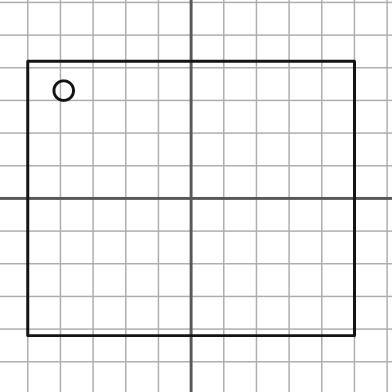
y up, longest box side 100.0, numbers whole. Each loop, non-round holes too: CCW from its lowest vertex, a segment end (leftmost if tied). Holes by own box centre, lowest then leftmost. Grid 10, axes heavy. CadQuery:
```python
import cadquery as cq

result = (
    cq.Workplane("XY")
    .moveTo(-50.0, -42.0)
    .lineTo(50.0, -42.0)
    .lineTo(50.0, 42.0)
    .lineTo(-50.0, 42.0)
    .close()
    .moveTo(-39.0, 33.0)
    .circle(3.0)
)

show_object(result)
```